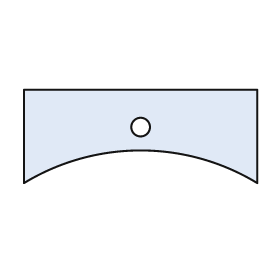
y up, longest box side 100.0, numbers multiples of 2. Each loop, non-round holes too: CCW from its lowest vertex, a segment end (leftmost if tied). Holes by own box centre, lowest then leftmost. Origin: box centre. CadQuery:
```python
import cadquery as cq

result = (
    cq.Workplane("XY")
    .moveTo(-50.0, -20.0)
    .threePointArc((0.0, -6.0), (50.0, -20.0))
    .lineTo(50.0, 20.0)
    .lineTo(-50.0, 20.0)
    .close()
    .moveTo(0.0, 4.0)
    .circle(4.0)
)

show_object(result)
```